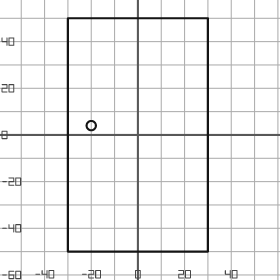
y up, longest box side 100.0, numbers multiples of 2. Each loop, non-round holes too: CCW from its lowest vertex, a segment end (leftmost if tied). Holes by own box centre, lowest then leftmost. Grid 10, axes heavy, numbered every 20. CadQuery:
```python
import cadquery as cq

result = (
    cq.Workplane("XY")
    .moveTo(-30.0, -50.0)
    .lineTo(30.0, -50.0)
    .lineTo(30.0, 50.0)
    .lineTo(-30.0, 50.0)
    .close()
    .moveTo(-20.0, 4.0)
    .circle(2.0)
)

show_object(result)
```